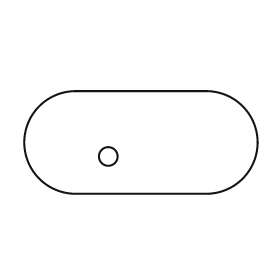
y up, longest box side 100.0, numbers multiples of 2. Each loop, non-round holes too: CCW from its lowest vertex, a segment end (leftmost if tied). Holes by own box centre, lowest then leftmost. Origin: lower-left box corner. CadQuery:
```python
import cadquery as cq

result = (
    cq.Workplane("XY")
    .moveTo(22.0, 0.0)
    .lineTo(78.0, 0.0)
    .threePointArc((100.0, 22.0), (78.0, 44.0))
    .lineTo(22.0, 44.0)
    .threePointArc((0.0, 22.0), (22.0, 0.0))
    .close()
    .moveTo(36.0, 16.0)
    .circle(4.0)
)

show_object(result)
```